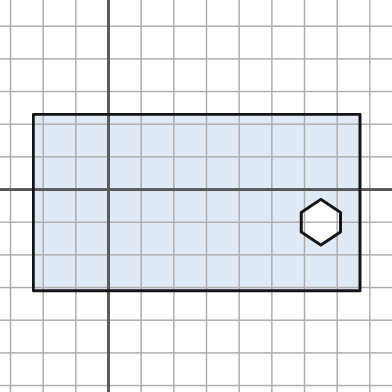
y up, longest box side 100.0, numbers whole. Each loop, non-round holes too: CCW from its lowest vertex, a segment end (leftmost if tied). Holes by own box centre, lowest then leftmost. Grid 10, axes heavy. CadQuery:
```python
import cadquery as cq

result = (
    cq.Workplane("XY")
    .moveTo(-23.0, -31.0)
    .lineTo(77.0, -31.0)
    .lineTo(77.0, 23.0)
    .lineTo(-23.0, 23.0)
    .close()
    .moveTo(65.0, -17.0)
    .lineTo(71.0, -13.0)
    .lineTo(71.0, -7.0)
    .lineTo(65.0, -3.0)
    .lineTo(59.0, -7.0)
    .lineTo(59.0, -13.0)
    .close()
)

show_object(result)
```